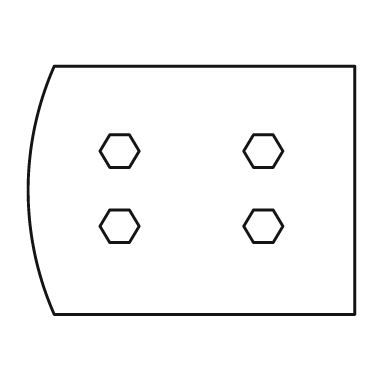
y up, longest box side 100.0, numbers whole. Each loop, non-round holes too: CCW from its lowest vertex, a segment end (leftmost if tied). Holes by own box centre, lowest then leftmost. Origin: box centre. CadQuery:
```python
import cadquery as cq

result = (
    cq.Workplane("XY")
    .moveTo(-42.0, -38.0)
    .lineTo(50.0, -38.0)
    .lineTo(50.0, 38.0)
    .lineTo(-42.0, 38.0)
    .threePointArc((-50.0, 0.0), (-42.0, -38.0))
    .close()
    .moveTo(-25.0, -16.0)
    .lineTo(-19.0, -16.0)
    .lineTo(-16.0, -11.0)
    .lineTo(-19.0, -6.0)
    .lineTo(-25.0, -6.0)
    .lineTo(-28.0, -11.0)
    .close()
    .moveTo(19.0, -16.0)
    .lineTo(25.0, -16.0)
    .lineTo(28.0, -11.0)
    .lineTo(25.0, -6.0)
    .lineTo(19.0, -6.0)
    .lineTo(16.0, -11.0)
    .close()
    .moveTo(-25.0, 7.0)
    .lineTo(-19.0, 7.0)
    .lineTo(-16.0, 12.0)
    .lineTo(-19.0, 17.0)
    .lineTo(-25.0, 17.0)
    .lineTo(-28.0, 12.0)
    .close()
    .moveTo(19.0, 7.0)
    .lineTo(25.0, 7.0)
    .lineTo(28.0, 12.0)
    .lineTo(25.0, 17.0)
    .lineTo(19.0, 17.0)
    .lineTo(16.0, 12.0)
    .close()
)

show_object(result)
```